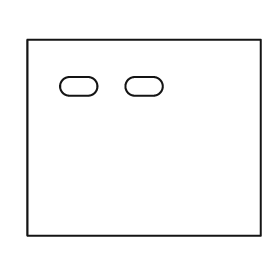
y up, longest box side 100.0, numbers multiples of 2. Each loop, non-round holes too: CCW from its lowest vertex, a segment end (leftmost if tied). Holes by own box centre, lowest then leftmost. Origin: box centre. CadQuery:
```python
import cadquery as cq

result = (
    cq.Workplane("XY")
    .moveTo(-50.0, -42.0)
    .lineTo(50.0, -42.0)
    .lineTo(50.0, 42.0)
    .lineTo(-50.0, 42.0)
    .close()
    .moveTo(-32.0, 18.0)
    .lineTo(-24.0, 18.0)
    .threePointArc((-20.0, 22.0), (-24.0, 26.0))
    .lineTo(-32.0, 26.0)
    .threePointArc((-36.0, 22.0), (-32.0, 18.0))
    .close()
    .moveTo(-4.0, 18.0)
    .lineTo(4.0, 18.0)
    .threePointArc((8.0, 22.0), (4.0, 26.0))
    .lineTo(-4.0, 26.0)
    .threePointArc((-8.0, 22.0), (-4.0, 18.0))
    .close()
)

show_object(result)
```